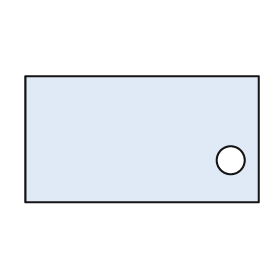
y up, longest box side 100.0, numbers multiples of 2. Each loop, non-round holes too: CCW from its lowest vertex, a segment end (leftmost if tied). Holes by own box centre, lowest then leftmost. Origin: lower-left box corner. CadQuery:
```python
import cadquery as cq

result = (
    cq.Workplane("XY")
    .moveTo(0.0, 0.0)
    .lineTo(100.0, 0.0)
    .lineTo(100.0, 54.0)
    .lineTo(0.0, 54.0)
    .close()
    .moveTo(88.0, 18.0)
    .circle(6.0)
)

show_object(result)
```